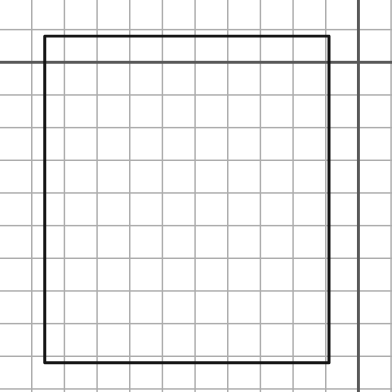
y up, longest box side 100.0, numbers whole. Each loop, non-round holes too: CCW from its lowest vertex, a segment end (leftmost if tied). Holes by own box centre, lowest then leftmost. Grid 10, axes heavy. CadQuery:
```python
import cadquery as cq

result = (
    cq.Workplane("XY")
    .moveTo(-96.0, -92.0)
    .lineTo(-9.0, -92.0)
    .lineTo(-9.0, 8.0)
    .lineTo(-96.0, 8.0)
    .close()
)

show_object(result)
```